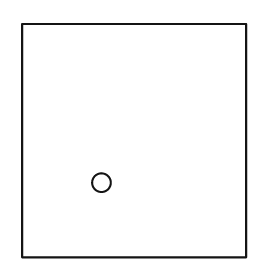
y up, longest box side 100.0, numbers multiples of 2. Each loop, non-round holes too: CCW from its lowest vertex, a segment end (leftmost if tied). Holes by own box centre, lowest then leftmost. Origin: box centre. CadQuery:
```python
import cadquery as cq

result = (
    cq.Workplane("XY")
    .moveTo(-48.0, -50.0)
    .lineTo(48.0, -50.0)
    .lineTo(48.0, 50.0)
    .lineTo(-48.0, 50.0)
    .close()
    .moveTo(-14.0, -18.0)
    .circle(4.0)
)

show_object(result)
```